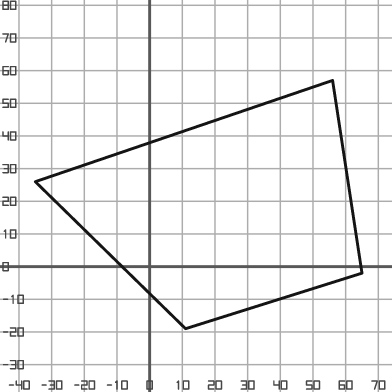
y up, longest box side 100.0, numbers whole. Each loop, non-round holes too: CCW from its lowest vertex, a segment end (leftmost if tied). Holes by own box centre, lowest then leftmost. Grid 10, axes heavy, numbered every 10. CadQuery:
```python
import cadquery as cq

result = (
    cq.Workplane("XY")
    .moveTo(11.0, -19.0)
    .lineTo(65.0, -2.0)
    .lineTo(56.0, 57.0)
    .lineTo(-35.0, 26.0)
    .close()
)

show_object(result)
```